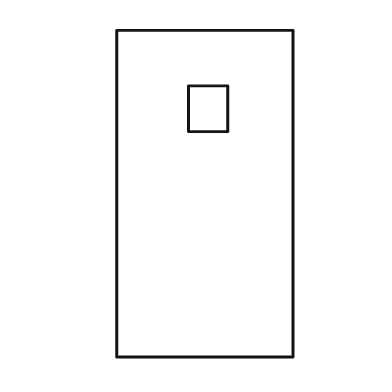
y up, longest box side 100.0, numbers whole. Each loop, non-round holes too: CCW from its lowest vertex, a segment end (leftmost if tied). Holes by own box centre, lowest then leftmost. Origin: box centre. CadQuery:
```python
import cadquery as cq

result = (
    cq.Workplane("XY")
    .moveTo(-27.0, -50.0)
    .lineTo(27.0, -50.0)
    .lineTo(27.0, 50.0)
    .lineTo(-27.0, 50.0)
    .close()
    .moveTo(-5.0, 19.0)
    .lineTo(7.0, 19.0)
    .lineTo(7.0, 33.0)
    .lineTo(-5.0, 33.0)
    .close()
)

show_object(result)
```